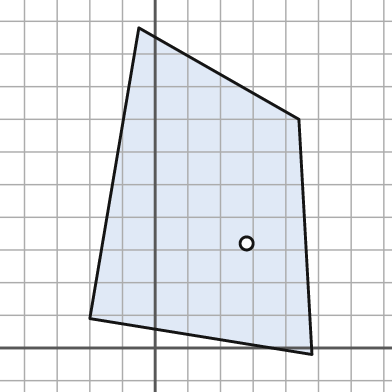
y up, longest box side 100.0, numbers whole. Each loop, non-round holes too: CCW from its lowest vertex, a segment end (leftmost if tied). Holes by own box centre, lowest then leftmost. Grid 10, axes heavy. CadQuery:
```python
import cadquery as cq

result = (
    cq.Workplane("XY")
    .moveTo(48.0, -2.0)
    .lineTo(44.0, 70.0)
    .lineTo(-5.0, 98.0)
    .lineTo(-20.0, 9.0)
    .close()
    .moveTo(28.0, 32.0)
    .circle(2.0)
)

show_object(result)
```